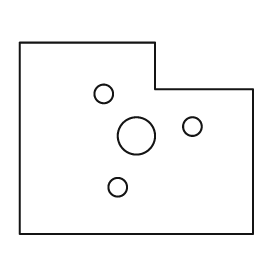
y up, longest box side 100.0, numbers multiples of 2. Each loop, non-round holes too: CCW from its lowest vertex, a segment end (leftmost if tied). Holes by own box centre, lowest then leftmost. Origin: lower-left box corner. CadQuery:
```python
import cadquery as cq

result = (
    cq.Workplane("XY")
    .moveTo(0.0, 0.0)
    .lineTo(100.0, 0.0)
    .lineTo(100.0, 62.0)
    .lineTo(58.0, 62.0)
    .lineTo(58.0, 82.0)
    .lineTo(0.0, 82.0)
    .close()
    .moveTo(42.0, 20.0)
    .circle(4.0)
    .moveTo(50.0, 42.0)
    .circle(8.0)
    .moveTo(74.0, 46.0)
    .circle(4.0)
    .moveTo(36.0, 60.0)
    .circle(4.0)
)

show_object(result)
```